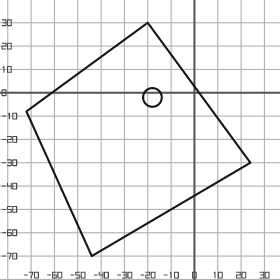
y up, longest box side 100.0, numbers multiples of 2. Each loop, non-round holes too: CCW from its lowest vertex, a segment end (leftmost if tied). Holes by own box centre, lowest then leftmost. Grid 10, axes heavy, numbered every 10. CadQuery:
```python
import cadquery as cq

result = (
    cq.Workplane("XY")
    .moveTo(-44.0, -70.0)
    .lineTo(24.0, -30.0)
    .lineTo(-20.0, 30.0)
    .lineTo(-72.0, -8.0)
    .close()
    .moveTo(-18.0, -2.0)
    .circle(4.0)
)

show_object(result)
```